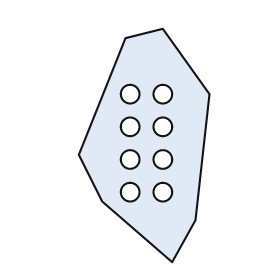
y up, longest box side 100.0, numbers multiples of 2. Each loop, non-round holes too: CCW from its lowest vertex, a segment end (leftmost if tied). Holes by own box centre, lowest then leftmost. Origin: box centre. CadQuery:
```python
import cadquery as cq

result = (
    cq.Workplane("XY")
    .moveTo(12.0, -50.0)
    .lineTo(22.0, -32.0)
    .lineTo(28.0, 22.0)
    .lineTo(8.0, 50.0)
    .lineTo(-8.0, 46.0)
    .lineTo(-28.0, -4.0)
    .lineTo(-18.0, -24.0)
    .close()
    .moveTo(-6.0, -20.0)
    .circle(4.0)
    .moveTo(8.0, -20.0)
    .circle(4.0)
    .moveTo(-6.0, -6.0)
    .circle(4.0)
    .moveTo(8.0, -6.0)
    .circle(4.0)
    .moveTo(-6.0, 8.0)
    .circle(4.0)
    .moveTo(8.0, 8.0)
    .circle(4.0)
    .moveTo(-6.0, 22.0)
    .circle(4.0)
    .moveTo(8.0, 22.0)
    .circle(4.0)
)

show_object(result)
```